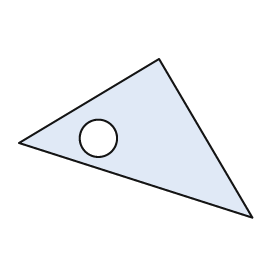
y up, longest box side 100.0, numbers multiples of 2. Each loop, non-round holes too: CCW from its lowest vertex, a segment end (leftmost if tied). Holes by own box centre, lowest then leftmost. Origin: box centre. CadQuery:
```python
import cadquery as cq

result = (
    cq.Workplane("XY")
    .moveTo(50.0, -34.0)
    .lineTo(10.0, 34.0)
    .lineTo(-50.0, -2.0)
    .close()
    .moveTo(-16.0, 0.0)
    .circle(8.0)
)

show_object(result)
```